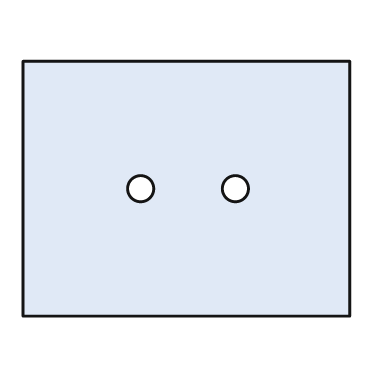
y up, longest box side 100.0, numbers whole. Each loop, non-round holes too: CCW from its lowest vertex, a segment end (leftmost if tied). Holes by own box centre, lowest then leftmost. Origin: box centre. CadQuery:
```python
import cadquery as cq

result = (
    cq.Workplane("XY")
    .moveTo(-50.0, -39.0)
    .lineTo(50.0, -39.0)
    .lineTo(50.0, 39.0)
    .lineTo(-50.0, 39.0)
    .close()
    .moveTo(-14.0, 0.0)
    .circle(4.0)
    .moveTo(15.0, 0.0)
    .circle(4.0)
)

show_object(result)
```